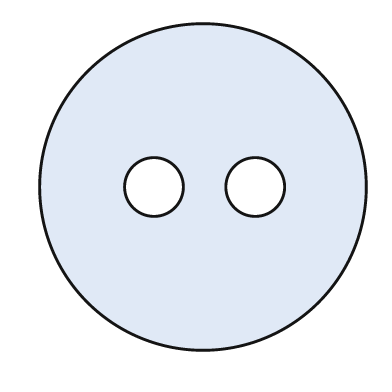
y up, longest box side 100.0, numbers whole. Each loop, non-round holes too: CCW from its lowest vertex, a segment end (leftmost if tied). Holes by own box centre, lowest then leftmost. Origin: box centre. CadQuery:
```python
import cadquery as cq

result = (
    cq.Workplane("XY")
    .moveTo(0.0, 0.0)
    .circle(50.0)
    .moveTo(-15.0, 0.0)
    .circle(9.0)
    .moveTo(16.0, 0.0)
    .circle(9.0)
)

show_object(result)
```